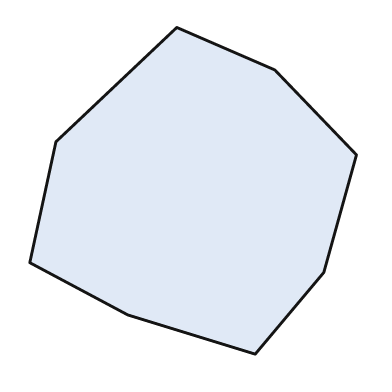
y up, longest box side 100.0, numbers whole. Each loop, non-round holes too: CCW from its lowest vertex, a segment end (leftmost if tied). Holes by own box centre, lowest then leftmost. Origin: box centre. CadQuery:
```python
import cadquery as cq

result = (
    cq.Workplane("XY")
    .moveTo(19.0, -50.0)
    .lineTo(40.0, -25.0)
    .lineTo(50.0, 11.0)
    .lineTo(25.0, 37.0)
    .lineTo(-5.0, 50.0)
    .lineTo(-42.0, 15.0)
    .lineTo(-50.0, -22.0)
    .lineTo(-20.0, -38.0)
    .close()
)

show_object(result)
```